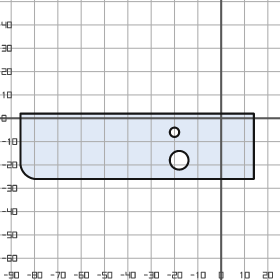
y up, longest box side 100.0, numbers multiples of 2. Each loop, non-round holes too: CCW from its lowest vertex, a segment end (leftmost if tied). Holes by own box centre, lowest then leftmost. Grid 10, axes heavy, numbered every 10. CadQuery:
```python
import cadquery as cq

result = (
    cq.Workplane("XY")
    .moveTo(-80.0, -26.0)
    .lineTo(14.0, -26.0)
    .lineTo(14.0, 2.0)
    .lineTo(-86.0, 2.0)
    .lineTo(-86.0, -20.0)
    .threePointArc((-84.0, -24.0), (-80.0, -26.0))
    .close()
    .moveTo(-18.0, -18.0)
    .circle(4.0)
    .moveTo(-20.0, -6.0)
    .circle(2.0)
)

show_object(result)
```